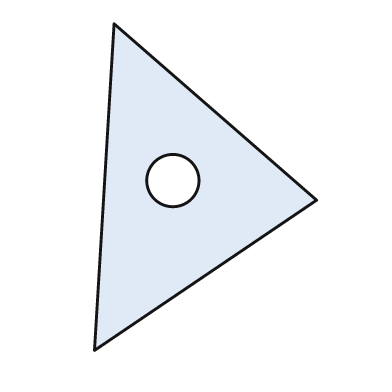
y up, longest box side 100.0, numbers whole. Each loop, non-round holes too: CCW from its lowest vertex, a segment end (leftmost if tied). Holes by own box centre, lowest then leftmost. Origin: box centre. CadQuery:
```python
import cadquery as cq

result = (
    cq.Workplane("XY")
    .moveTo(-34.0, -50.0)
    .lineTo(34.0, -4.0)
    .lineTo(-28.0, 50.0)
    .close()
    .moveTo(-10.0, 2.0)
    .circle(8.0)
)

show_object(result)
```